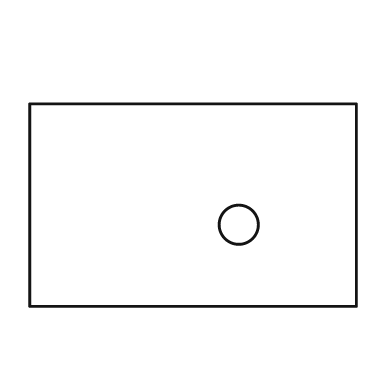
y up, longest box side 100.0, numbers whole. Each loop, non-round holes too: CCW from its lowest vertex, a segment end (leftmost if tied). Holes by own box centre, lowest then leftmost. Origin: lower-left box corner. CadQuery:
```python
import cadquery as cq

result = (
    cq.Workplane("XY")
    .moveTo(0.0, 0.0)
    .lineTo(100.0, 0.0)
    .lineTo(100.0, 62.0)
    .lineTo(0.0, 62.0)
    .close()
    .moveTo(64.0, 25.0)
    .circle(6.0)
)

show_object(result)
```